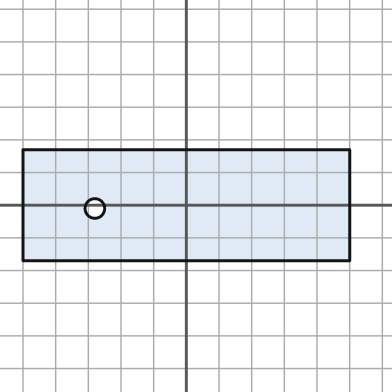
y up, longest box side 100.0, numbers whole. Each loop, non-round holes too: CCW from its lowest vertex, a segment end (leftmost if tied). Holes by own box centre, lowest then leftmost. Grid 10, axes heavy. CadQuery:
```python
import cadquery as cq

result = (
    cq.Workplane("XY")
    .moveTo(-50.0, -17.0)
    .lineTo(50.0, -17.0)
    .lineTo(50.0, 17.0)
    .lineTo(-50.0, 17.0)
    .close()
    .moveTo(-28.0, -1.0)
    .circle(3.0)
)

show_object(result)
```